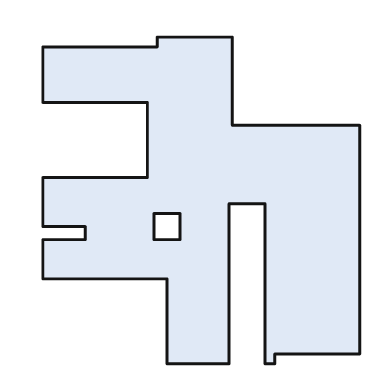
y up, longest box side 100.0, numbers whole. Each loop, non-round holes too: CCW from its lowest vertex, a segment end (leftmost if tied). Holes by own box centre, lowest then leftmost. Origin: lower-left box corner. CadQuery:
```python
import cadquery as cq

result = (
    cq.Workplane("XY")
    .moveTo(38.0, 0.0)
    .lineTo(57.0, 0.0)
    .lineTo(57.0, 49.0)
    .lineTo(68.0, 49.0)
    .lineTo(68.0, 0.0)
    .lineTo(71.0, 0.0)
    .lineTo(71.0, 3.0)
    .lineTo(97.0, 3.0)
    .lineTo(97.0, 73.0)
    .lineTo(58.0, 73.0)
    .lineTo(58.0, 100.0)
    .lineTo(35.0, 100.0)
    .lineTo(35.0, 97.0)
    .lineTo(0.0, 97.0)
    .lineTo(0.0, 80.0)
    .lineTo(32.0, 80.0)
    .lineTo(32.0, 57.0)
    .lineTo(0.0, 57.0)
    .lineTo(0.0, 42.0)
    .lineTo(13.0, 42.0)
    .lineTo(13.0, 38.0)
    .lineTo(0.0, 38.0)
    .lineTo(0.0, 26.0)
    .lineTo(38.0, 26.0)
    .close()
    .moveTo(34.0, 38.0)
    .lineTo(42.0, 38.0)
    .lineTo(42.0, 46.0)
    .lineTo(34.0, 46.0)
    .close()
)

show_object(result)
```